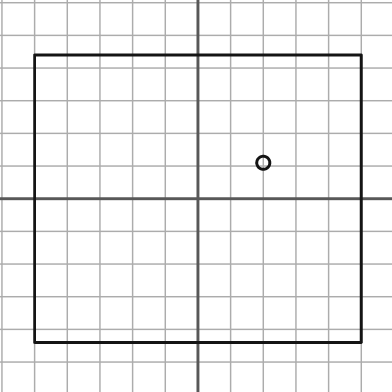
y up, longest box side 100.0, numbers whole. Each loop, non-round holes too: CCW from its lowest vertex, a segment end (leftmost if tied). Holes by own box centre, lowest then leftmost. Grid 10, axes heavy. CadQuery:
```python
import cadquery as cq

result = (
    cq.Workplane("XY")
    .moveTo(-50.0, -44.0)
    .lineTo(50.0, -44.0)
    .lineTo(50.0, 44.0)
    .lineTo(-50.0, 44.0)
    .close()
    .moveTo(20.0, 11.0)
    .circle(2.0)
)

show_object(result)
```